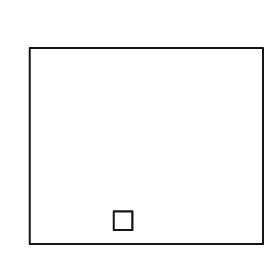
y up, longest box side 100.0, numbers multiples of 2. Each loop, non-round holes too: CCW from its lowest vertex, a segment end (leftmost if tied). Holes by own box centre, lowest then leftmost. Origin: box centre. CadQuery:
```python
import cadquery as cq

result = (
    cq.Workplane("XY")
    .moveTo(-50.0, -42.0)
    .lineTo(50.0, -42.0)
    .lineTo(50.0, 42.0)
    .lineTo(-50.0, 42.0)
    .close()
    .moveTo(-14.0, -36.0)
    .lineTo(-6.0, -36.0)
    .lineTo(-6.0, -28.0)
    .lineTo(-14.0, -28.0)
    .close()
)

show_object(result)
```